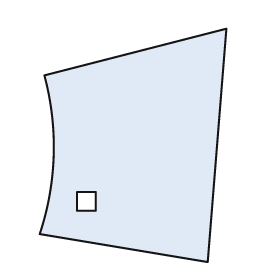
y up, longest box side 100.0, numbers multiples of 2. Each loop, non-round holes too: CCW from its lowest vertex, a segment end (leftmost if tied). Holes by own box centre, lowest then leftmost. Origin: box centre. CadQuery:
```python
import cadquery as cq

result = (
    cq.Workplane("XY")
    .moveTo(32.0, -50.0)
    .lineTo(40.0, 50.0)
    .lineTo(-38.0, 30.0)
    .threePointArc((-34.0, -4.0), (-40.0, -38.0))
    .close()
    .moveTo(-24.0, -28.0)
    .lineTo(-16.0, -28.0)
    .lineTo(-16.0, -20.0)
    .lineTo(-24.0, -20.0)
    .close()
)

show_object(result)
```